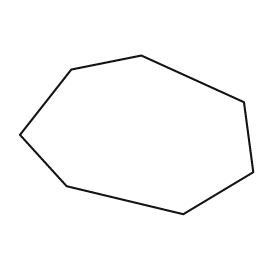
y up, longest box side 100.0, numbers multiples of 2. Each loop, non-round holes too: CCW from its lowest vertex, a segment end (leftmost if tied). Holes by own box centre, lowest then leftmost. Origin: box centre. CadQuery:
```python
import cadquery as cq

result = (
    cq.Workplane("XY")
    .moveTo(20.0, -34.0)
    .lineTo(50.0, -16.0)
    .lineTo(46.0, 14.0)
    .lineTo(2.0, 34.0)
    .lineTo(-28.0, 28.0)
    .lineTo(-50.0, 0.0)
    .lineTo(-30.0, -22.0)
    .close()
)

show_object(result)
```